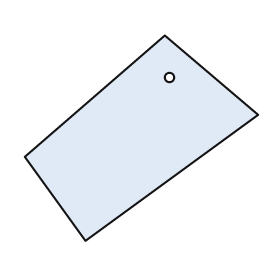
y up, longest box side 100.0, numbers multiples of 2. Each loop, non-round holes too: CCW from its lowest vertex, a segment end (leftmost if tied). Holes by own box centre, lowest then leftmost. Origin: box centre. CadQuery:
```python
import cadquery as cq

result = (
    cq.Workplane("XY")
    .moveTo(-24.0, -44.0)
    .lineTo(50.0, 10.0)
    .lineTo(10.0, 44.0)
    .lineTo(-50.0, -8.0)
    .close()
    .moveTo(12.0, 26.0)
    .circle(2.0)
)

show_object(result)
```